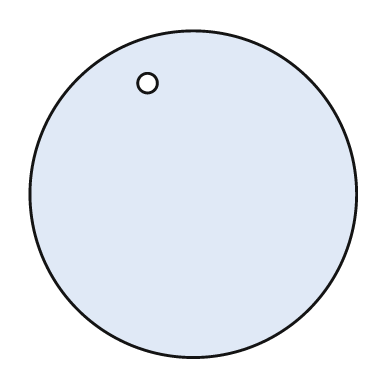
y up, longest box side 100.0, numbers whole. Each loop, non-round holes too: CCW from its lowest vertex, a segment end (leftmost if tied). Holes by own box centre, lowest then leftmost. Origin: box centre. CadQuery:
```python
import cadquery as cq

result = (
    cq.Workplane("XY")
    .moveTo(0.0, 0.0)
    .circle(50.0)
    .moveTo(-14.0, 34.0)
    .circle(3.0)
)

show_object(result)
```